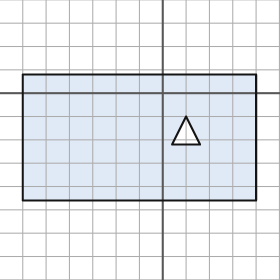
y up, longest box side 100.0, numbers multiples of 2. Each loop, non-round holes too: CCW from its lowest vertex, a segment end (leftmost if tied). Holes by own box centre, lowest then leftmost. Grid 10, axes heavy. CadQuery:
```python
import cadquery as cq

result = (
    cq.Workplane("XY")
    .moveTo(-60.0, -46.0)
    .lineTo(40.0, -46.0)
    .lineTo(40.0, 8.0)
    .lineTo(-60.0, 8.0)
    .close()
    .moveTo(4.0, -22.0)
    .lineTo(16.0, -22.0)
    .lineTo(10.0, -10.0)
    .close()
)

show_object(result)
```